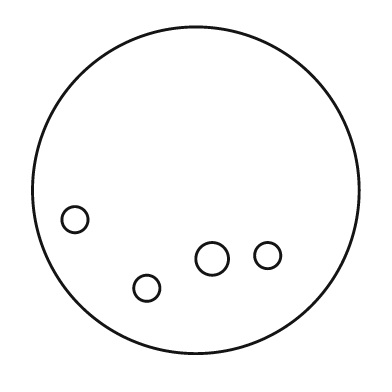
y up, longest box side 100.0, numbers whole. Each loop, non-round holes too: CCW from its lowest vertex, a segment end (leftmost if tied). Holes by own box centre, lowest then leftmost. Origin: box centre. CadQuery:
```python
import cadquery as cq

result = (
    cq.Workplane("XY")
    .moveTo(0.0, 0.0)
    .circle(50.0)
    .moveTo(-15.0, -30.0)
    .circle(4.0)
    .moveTo(5.0, -21.0)
    .circle(5.0)
    .moveTo(22.0, -20.0)
    .circle(4.0)
    .moveTo(-37.0, -9.0)
    .circle(4.0)
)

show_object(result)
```